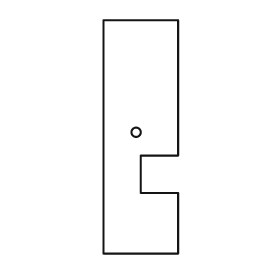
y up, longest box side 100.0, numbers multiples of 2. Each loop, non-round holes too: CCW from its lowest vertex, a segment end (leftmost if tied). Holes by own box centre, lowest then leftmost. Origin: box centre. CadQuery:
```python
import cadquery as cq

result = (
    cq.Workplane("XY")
    .moveTo(-16.0, -50.0)
    .lineTo(16.0, -50.0)
    .lineTo(16.0, -24.0)
    .lineTo(0.0, -24.0)
    .lineTo(0.0, -8.0)
    .lineTo(16.0, -8.0)
    .lineTo(16.0, 50.0)
    .lineTo(-16.0, 50.0)
    .close()
    .moveTo(-2.0, 2.0)
    .circle(2.0)
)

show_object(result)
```